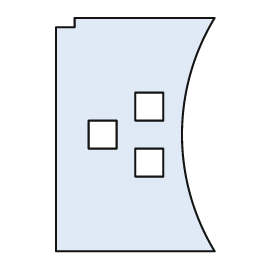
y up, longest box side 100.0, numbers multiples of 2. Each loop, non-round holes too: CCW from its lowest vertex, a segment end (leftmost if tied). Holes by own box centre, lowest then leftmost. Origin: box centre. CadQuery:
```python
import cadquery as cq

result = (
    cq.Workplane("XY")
    .moveTo(-34.0, -50.0)
    .lineTo(34.0, -50.0)
    .threePointArc((20.0, 0.0), (34.0, 50.0))
    .lineTo(-26.0, 50.0)
    .lineTo(-26.0, 46.0)
    .lineTo(-34.0, 46.0)
    .close()
    .moveTo(0.0, -18.0)
    .lineTo(12.0, -18.0)
    .lineTo(12.0, -6.0)
    .lineTo(0.0, -6.0)
    .close()
    .moveTo(-20.0, -6.0)
    .lineTo(-8.0, -6.0)
    .lineTo(-8.0, 6.0)
    .lineTo(-20.0, 6.0)
    .close()
    .moveTo(0.0, 6.0)
    .lineTo(12.0, 6.0)
    .lineTo(12.0, 18.0)
    .lineTo(0.0, 18.0)
    .close()
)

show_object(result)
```